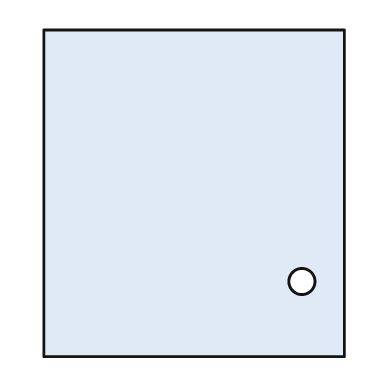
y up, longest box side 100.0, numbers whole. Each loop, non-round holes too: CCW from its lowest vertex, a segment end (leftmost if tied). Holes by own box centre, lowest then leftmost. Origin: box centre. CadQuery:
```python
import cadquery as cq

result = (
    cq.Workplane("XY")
    .moveTo(-46.0, -50.0)
    .lineTo(46.0, -50.0)
    .lineTo(46.0, 50.0)
    .lineTo(-46.0, 50.0)
    .close()
    .moveTo(33.0, -27.0)
    .circle(4.0)
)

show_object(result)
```